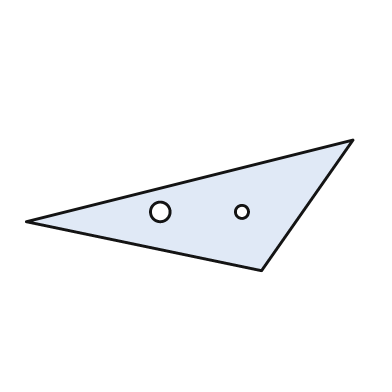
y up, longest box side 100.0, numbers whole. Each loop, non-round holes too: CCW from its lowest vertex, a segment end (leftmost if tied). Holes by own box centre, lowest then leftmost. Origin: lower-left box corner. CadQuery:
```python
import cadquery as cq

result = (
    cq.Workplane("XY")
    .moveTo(72.0, 0.0)
    .lineTo(100.0, 40.0)
    .lineTo(0.0, 15.0)
    .close()
    .moveTo(41.0, 18.0)
    .circle(3.0)
    .moveTo(66.0, 18.0)
    .circle(2.0)
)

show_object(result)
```